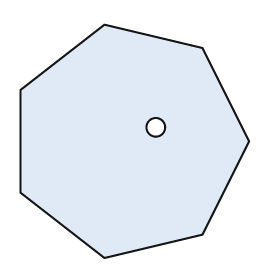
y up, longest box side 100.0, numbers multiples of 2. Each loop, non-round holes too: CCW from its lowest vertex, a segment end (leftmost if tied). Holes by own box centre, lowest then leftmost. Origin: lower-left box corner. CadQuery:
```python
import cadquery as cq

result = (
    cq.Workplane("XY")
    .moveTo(36.0, 0.0)
    .lineTo(78.0, 10.0)
    .lineTo(98.0, 50.0)
    .lineTo(78.0, 90.0)
    .lineTo(36.0, 100.0)
    .lineTo(0.0, 72.0)
    .lineTo(0.0, 28.0)
    .close()
    .moveTo(58.0, 56.0)
    .circle(4.0)
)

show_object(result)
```